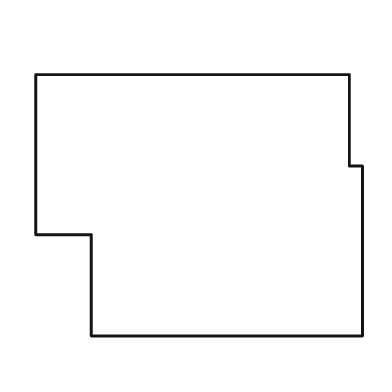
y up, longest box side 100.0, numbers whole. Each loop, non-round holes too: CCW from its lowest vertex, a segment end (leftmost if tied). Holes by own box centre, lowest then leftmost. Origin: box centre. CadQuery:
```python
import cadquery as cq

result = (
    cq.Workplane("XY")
    .moveTo(-33.0, -40.0)
    .lineTo(50.0, -40.0)
    .lineTo(50.0, 12.0)
    .lineTo(46.0, 12.0)
    .lineTo(46.0, 40.0)
    .lineTo(-50.0, 40.0)
    .lineTo(-50.0, -9.0)
    .lineTo(-33.0, -9.0)
    .close()
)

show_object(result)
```